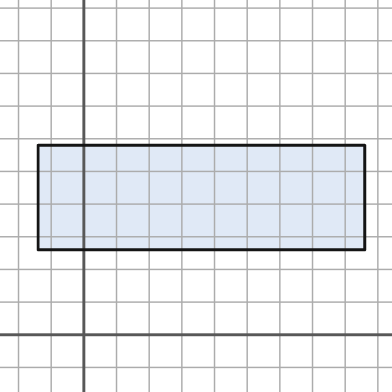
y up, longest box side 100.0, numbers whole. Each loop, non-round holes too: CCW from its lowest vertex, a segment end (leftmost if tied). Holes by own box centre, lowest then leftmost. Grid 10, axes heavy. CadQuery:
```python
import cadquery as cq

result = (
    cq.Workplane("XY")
    .moveTo(-14.0, 26.0)
    .lineTo(86.0, 26.0)
    .lineTo(86.0, 58.0)
    .lineTo(-14.0, 58.0)
    .close()
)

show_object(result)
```